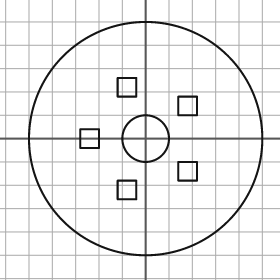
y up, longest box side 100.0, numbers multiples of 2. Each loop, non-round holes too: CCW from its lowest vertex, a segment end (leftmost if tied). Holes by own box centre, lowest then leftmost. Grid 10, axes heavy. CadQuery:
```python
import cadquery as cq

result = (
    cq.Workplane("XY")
    .moveTo(0.0, 0.0)
    .circle(50.0)
    .moveTo(-12.0, -26.0)
    .lineTo(-4.0, -26.0)
    .lineTo(-4.0, -18.0)
    .lineTo(-12.0, -18.0)
    .close()
    .moveTo(14.0, -18.0)
    .lineTo(22.0, -18.0)
    .lineTo(22.0, -10.0)
    .lineTo(14.0, -10.0)
    .close()
    .moveTo(-28.0, -4.0)
    .lineTo(-20.0, -4.0)
    .lineTo(-20.0, 4.0)
    .lineTo(-28.0, 4.0)
    .close()
    .moveTo(0.0, 0.0)
    .circle(10.0)
    .moveTo(14.0, 10.0)
    .lineTo(22.0, 10.0)
    .lineTo(22.0, 18.0)
    .lineTo(14.0, 18.0)
    .close()
    .moveTo(-12.0, 18.0)
    .lineTo(-4.0, 18.0)
    .lineTo(-4.0, 26.0)
    .lineTo(-12.0, 26.0)
    .close()
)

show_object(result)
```